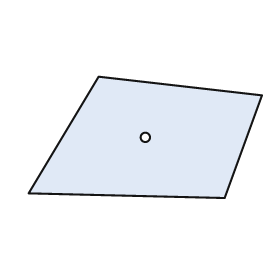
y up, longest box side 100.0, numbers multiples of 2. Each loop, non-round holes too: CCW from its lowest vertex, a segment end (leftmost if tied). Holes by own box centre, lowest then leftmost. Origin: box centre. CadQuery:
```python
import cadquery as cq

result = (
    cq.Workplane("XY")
    .moveTo(34.0, -26.0)
    .lineTo(50.0, 18.0)
    .lineTo(-20.0, 26.0)
    .lineTo(-50.0, -24.0)
    .close()
    .moveTo(0.0, 0.0)
    .circle(2.0)
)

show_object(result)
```